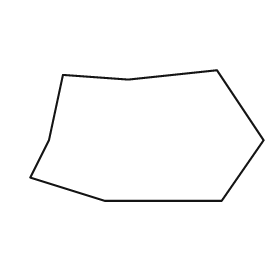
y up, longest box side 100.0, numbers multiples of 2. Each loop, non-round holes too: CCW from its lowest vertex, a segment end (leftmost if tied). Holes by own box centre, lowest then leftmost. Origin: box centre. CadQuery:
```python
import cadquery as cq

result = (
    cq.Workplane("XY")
    .moveTo(-18.0, -28.0)
    .lineTo(32.0, -28.0)
    .lineTo(50.0, -2.0)
    .lineTo(30.0, 28.0)
    .lineTo(-8.0, 24.0)
    .lineTo(-36.0, 26.0)
    .lineTo(-42.0, -2.0)
    .lineTo(-50.0, -18.0)
    .close()
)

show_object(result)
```